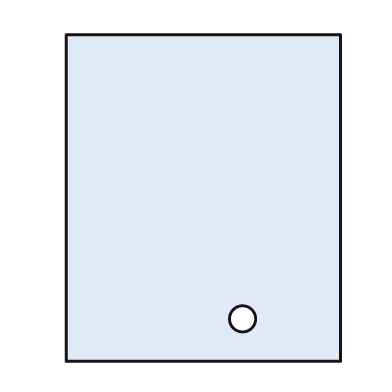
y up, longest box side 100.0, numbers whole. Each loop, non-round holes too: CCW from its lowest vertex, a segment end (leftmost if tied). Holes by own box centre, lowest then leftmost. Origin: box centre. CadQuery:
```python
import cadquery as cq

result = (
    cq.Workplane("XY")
    .moveTo(-42.0, -50.0)
    .lineTo(42.0, -50.0)
    .lineTo(42.0, 50.0)
    .lineTo(-42.0, 50.0)
    .close()
    .moveTo(12.0, -37.0)
    .circle(4.0)
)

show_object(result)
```